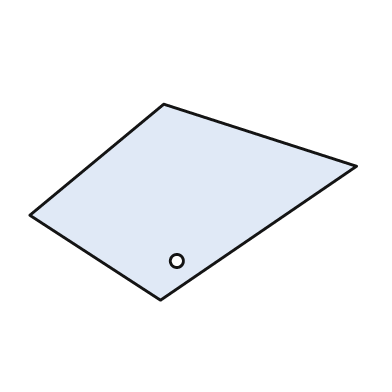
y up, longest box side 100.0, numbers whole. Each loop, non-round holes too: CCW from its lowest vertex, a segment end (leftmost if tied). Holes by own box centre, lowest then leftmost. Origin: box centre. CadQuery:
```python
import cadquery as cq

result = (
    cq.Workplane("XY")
    .moveTo(-10.0, -30.0)
    .lineTo(50.0, 11.0)
    .lineTo(-9.0, 30.0)
    .lineTo(-50.0, -4.0)
    .close()
    .moveTo(-5.0, -18.0)
    .circle(2.0)
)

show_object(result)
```